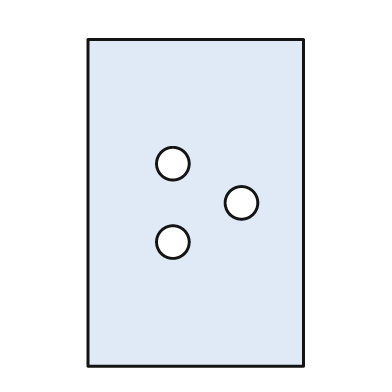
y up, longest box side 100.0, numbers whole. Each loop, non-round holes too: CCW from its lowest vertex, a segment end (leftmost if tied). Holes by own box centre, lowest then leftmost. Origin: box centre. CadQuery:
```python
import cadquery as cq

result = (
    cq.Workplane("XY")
    .moveTo(-33.0, -50.0)
    .lineTo(33.0, -50.0)
    .lineTo(33.0, 50.0)
    .lineTo(-33.0, 50.0)
    .close()
    .moveTo(-7.0, -12.0)
    .circle(5.0)
    .moveTo(14.0, 0.0)
    .circle(5.0)
    .moveTo(-7.0, 12.0)
    .circle(5.0)
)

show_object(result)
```